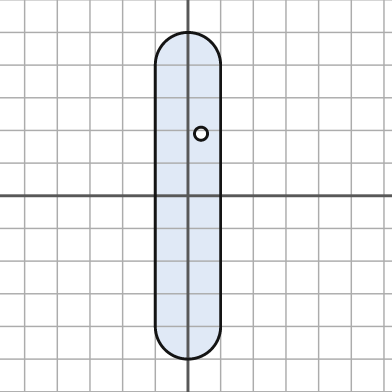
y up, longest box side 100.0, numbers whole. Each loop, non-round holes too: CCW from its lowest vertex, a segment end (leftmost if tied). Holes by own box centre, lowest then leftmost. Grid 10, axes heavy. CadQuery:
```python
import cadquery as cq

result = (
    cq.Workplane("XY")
    .moveTo(-10.0, -40.0)
    .threePointArc((0.0, -50.0), (10.0, -40.0))
    .lineTo(10.0, 40.0)
    .threePointArc((0.0, 50.0), (-10.0, 40.0))
    .close()
    .moveTo(4.0, 19.0)
    .circle(2.0)
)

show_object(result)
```